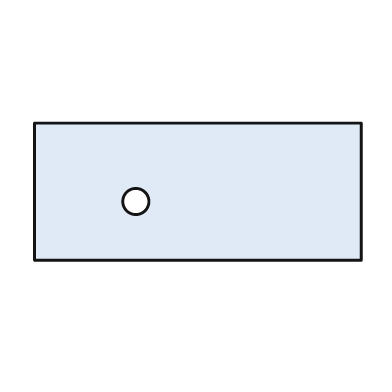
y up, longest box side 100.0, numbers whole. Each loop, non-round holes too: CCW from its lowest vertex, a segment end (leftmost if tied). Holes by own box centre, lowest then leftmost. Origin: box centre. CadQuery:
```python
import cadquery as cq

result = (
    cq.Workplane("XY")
    .moveTo(-50.0, -21.0)
    .lineTo(50.0, -21.0)
    .lineTo(50.0, 21.0)
    .lineTo(-50.0, 21.0)
    .close()
    .moveTo(-19.0, -3.0)
    .circle(4.0)
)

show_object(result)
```